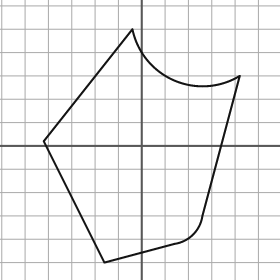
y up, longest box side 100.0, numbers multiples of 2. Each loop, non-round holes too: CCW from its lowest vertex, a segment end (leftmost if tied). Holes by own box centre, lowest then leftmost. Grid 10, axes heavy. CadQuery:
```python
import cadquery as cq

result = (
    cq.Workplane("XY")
    .moveTo(-16.0, -50.0)
    .lineTo(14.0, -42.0)
    .threePointArc((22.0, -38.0), (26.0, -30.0))
    .lineTo(42.0, 30.0)
    .threePointArc((14.0, 28.0), (-4.0, 50.0))
    .lineTo(-42.0, 2.0)
    .close()
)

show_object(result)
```